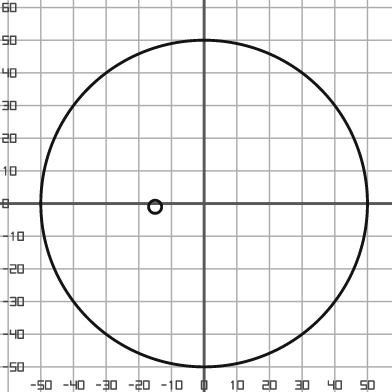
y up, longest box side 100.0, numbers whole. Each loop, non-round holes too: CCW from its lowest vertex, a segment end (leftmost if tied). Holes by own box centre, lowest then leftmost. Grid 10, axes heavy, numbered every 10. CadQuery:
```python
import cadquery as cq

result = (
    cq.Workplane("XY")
    .moveTo(0.0, 0.0)
    .circle(50.0)
    .moveTo(-15.0, -1.0)
    .circle(2.0)
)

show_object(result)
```